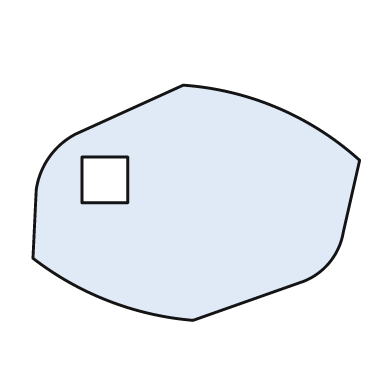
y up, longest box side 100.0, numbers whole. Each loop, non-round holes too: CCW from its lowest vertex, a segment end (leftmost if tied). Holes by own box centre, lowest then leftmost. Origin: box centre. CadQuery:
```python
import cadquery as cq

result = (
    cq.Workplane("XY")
    .moveTo(-1.0, -36.0)
    .lineTo(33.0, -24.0)
    .threePointArc((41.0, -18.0), (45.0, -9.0))
    .lineTo(50.0, 13.0)
    .threePointArc((25.0, 29.0), (-4.0, 36.0))
    .lineTo(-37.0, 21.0)
    .threePointArc((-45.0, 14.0), (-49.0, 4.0))
    .lineTo(-50.0, -17.0)
    .threePointArc((-27.0, -30.0), (-1.0, -36.0))
    .close()
    .moveTo(-35.0, 0.0)
    .lineTo(-21.0, 0.0)
    .lineTo(-21.0, 14.0)
    .lineTo(-35.0, 14.0)
    .close()
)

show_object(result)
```